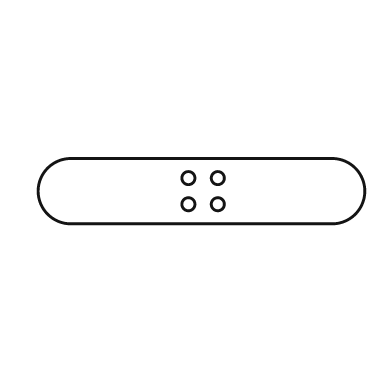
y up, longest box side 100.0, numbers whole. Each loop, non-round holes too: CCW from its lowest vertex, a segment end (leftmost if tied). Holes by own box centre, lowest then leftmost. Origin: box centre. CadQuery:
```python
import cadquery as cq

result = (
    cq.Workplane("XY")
    .moveTo(-40.0, -10.0)
    .lineTo(40.0, -10.0)
    .threePointArc((50.0, 0.0), (40.0, 10.0))
    .lineTo(-40.0, 10.0)
    .threePointArc((-50.0, 0.0), (-40.0, -10.0))
    .close()
    .moveTo(-4.0, -4.0)
    .circle(2.0)
    .moveTo(5.0, -4.0)
    .circle(2.0)
    .moveTo(-4.0, 4.0)
    .circle(2.0)
    .moveTo(5.0, 4.0)
    .circle(2.0)
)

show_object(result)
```